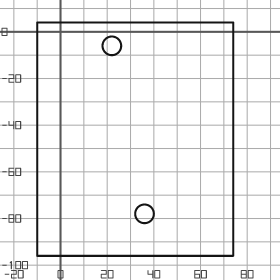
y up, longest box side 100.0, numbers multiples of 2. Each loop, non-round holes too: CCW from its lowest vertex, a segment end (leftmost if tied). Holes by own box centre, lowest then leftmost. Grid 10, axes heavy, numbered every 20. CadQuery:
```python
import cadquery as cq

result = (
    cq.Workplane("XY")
    .moveTo(-10.0, -96.0)
    .lineTo(74.0, -96.0)
    .lineTo(74.0, 4.0)
    .lineTo(-10.0, 4.0)
    .close()
    .moveTo(36.0, -78.0)
    .circle(4.0)
    .moveTo(22.0, -6.0)
    .circle(4.0)
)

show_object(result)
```